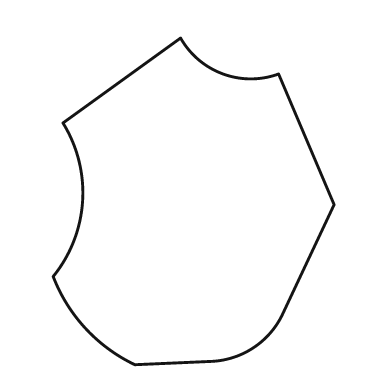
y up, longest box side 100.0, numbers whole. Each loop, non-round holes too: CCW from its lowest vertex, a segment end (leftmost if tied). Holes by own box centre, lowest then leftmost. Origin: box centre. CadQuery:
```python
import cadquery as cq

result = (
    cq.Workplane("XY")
    .moveTo(-18.0, -50.0)
    .lineTo(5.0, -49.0)
    .threePointArc((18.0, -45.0), (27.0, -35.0))
    .lineTo(43.0, -1.0)
    .lineTo(26.0, 39.0)
    .threePointArc((9.0, 39.0), (-4.0, 50.0))
    .lineTo(-40.0, 24.0)
    .threePointArc((-34.0, 0.0), (-43.0, -23.0))
    .threePointArc((-33.0, -39.0), (-18.0, -50.0))
    .close()
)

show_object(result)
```